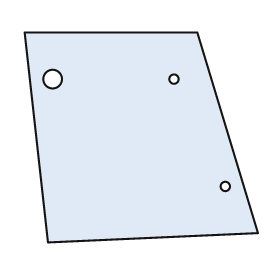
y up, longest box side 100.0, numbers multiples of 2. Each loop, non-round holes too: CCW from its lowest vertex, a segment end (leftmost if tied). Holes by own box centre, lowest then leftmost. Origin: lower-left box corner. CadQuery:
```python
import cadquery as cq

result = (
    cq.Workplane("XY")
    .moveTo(10.0, 0.0)
    .lineTo(100.0, 4.0)
    .lineTo(74.0, 90.0)
    .lineTo(0.0, 90.0)
    .close()
    .moveTo(86.0, 24.0)
    .circle(2.0)
    .moveTo(12.0, 70.0)
    .circle(4.0)
    .moveTo(64.0, 70.0)
    .circle(2.0)
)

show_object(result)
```